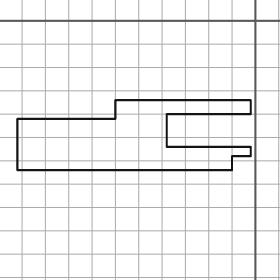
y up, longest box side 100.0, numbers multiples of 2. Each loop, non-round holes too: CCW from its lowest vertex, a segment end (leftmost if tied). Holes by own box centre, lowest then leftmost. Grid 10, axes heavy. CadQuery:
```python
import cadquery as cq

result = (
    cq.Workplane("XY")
    .moveTo(-102.0, -64.0)
    .lineTo(-10.0, -64.0)
    .lineTo(-10.0, -58.0)
    .lineTo(-2.0, -58.0)
    .lineTo(-2.0, -54.0)
    .lineTo(-38.0, -54.0)
    .lineTo(-38.0, -40.0)
    .lineTo(-2.0, -40.0)
    .lineTo(-2.0, -34.0)
    .lineTo(-60.0, -34.0)
    .lineTo(-60.0, -42.0)
    .lineTo(-102.0, -42.0)
    .close()
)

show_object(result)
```